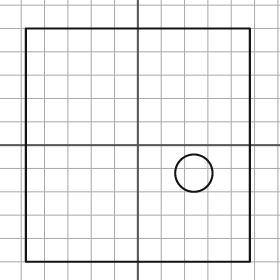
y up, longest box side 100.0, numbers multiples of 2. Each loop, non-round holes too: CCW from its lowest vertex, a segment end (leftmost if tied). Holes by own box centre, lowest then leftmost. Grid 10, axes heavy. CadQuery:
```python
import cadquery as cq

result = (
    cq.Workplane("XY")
    .moveTo(-48.0, -50.0)
    .lineTo(48.0, -50.0)
    .lineTo(48.0, 50.0)
    .lineTo(-48.0, 50.0)
    .close()
    .moveTo(24.0, -12.0)
    .circle(8.0)
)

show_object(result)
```